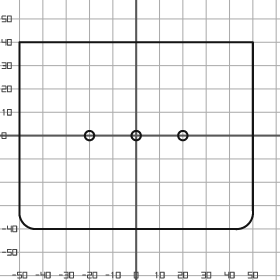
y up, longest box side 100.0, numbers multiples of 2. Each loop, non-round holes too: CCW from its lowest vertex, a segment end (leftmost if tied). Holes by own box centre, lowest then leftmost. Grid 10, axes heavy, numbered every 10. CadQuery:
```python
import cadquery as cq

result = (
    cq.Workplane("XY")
    .moveTo(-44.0, -40.0)
    .lineTo(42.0, -40.0)
    .threePointArc((48.0, -38.0), (50.0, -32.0))
    .lineTo(50.0, 40.0)
    .lineTo(-50.0, 40.0)
    .lineTo(-50.0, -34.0)
    .threePointArc((-48.0, -38.0), (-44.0, -40.0))
    .close()
    .moveTo(-20.0, 0.0)
    .circle(2.0)
    .moveTo(0.0, 0.0)
    .circle(2.0)
    .moveTo(20.0, 0.0)
    .circle(2.0)
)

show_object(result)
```